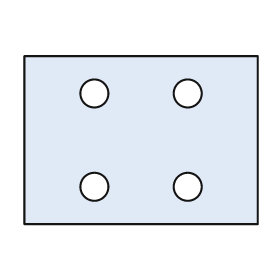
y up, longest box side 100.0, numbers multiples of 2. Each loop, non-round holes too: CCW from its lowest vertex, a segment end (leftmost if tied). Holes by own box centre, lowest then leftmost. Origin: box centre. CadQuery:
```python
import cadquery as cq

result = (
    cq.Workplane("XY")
    .moveTo(-50.0, -36.0)
    .lineTo(50.0, -36.0)
    .lineTo(50.0, 36.0)
    .lineTo(-50.0, 36.0)
    .close()
    .moveTo(-20.0, -20.0)
    .circle(6.0)
    .moveTo(20.0, -20.0)
    .circle(6.0)
    .moveTo(-20.0, 20.0)
    .circle(6.0)
    .moveTo(20.0, 20.0)
    .circle(6.0)
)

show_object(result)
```